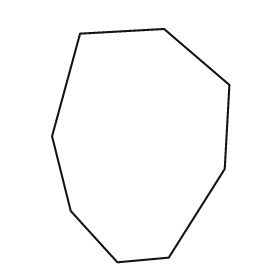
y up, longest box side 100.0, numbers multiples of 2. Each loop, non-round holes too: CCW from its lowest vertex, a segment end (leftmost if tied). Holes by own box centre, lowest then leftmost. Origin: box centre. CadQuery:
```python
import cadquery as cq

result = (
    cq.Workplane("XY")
    .moveTo(-10.0, -50.0)
    .lineTo(12.0, -48.0)
    .lineTo(36.0, -10.0)
    .lineTo(38.0, 26.0)
    .lineTo(10.0, 50.0)
    .lineTo(-26.0, 48.0)
    .lineTo(-38.0, 4.0)
    .lineTo(-30.0, -28.0)
    .close()
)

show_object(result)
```